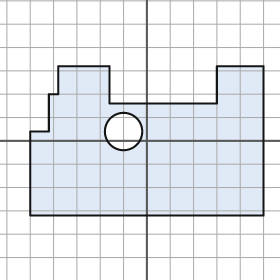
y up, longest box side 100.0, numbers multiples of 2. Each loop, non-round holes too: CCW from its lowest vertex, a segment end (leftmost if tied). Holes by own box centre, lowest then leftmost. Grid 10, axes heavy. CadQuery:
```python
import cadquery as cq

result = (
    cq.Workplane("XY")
    .moveTo(-50.0, -32.0)
    .lineTo(50.0, -32.0)
    .lineTo(50.0, 32.0)
    .lineTo(30.0, 32.0)
    .lineTo(30.0, 16.0)
    .lineTo(-16.0, 16.0)
    .lineTo(-16.0, 32.0)
    .lineTo(-38.0, 32.0)
    .lineTo(-38.0, 20.0)
    .lineTo(-42.0, 20.0)
    .lineTo(-42.0, 4.0)
    .lineTo(-50.0, 4.0)
    .close()
    .moveTo(-10.0, 4.0)
    .circle(8.0)
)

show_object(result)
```